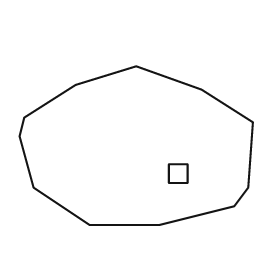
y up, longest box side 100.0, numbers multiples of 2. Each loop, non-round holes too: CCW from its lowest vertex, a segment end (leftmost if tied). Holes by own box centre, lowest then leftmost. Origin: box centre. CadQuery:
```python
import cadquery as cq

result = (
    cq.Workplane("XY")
    .moveTo(-20.0, -34.0)
    .lineTo(10.0, -34.0)
    .lineTo(42.0, -26.0)
    .lineTo(48.0, -18.0)
    .lineTo(50.0, 10.0)
    .lineTo(28.0, 24.0)
    .lineTo(0.0, 34.0)
    .lineTo(-26.0, 26.0)
    .lineTo(-48.0, 12.0)
    .lineTo(-50.0, 4.0)
    .lineTo(-44.0, -18.0)
    .close()
    .moveTo(14.0, -16.0)
    .lineTo(22.0, -16.0)
    .lineTo(22.0, -8.0)
    .lineTo(14.0, -8.0)
    .close()
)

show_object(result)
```